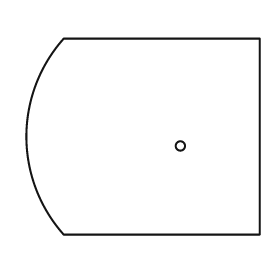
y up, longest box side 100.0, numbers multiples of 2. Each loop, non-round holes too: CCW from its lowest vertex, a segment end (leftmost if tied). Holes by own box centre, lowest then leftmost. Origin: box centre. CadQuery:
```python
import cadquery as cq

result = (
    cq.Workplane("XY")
    .moveTo(-34.0, -42.0)
    .lineTo(50.0, -42.0)
    .lineTo(50.0, 42.0)
    .lineTo(-34.0, 42.0)
    .threePointArc((-50.0, 0.0), (-34.0, -42.0))
    .close()
    .moveTo(16.0, -4.0)
    .circle(2.0)
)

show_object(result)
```